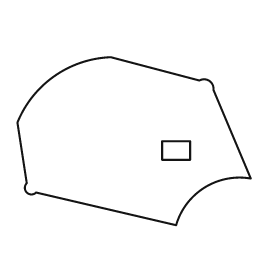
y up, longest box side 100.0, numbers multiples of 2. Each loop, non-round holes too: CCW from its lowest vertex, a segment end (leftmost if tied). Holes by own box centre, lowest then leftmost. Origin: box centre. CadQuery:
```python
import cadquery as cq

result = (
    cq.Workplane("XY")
    .moveTo(18.0, -36.0)
    .threePointArc((30.0, -20.0), (50.0, -16.0))
    .lineTo(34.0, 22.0)
    .threePointArc((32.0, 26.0), (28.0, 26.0))
    .lineTo(-10.0, 36.0)
    .threePointArc((-34.0, 28.0), (-50.0, 8.0))
    .lineTo(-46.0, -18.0)
    .threePointArc((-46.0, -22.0), (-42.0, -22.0))
    .close()
    .moveTo(12.0, -8.0)
    .lineTo(24.0, -8.0)
    .lineTo(24.0, 0.0)
    .lineTo(12.0, 0.0)
    .close()
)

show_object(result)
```